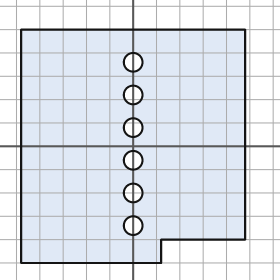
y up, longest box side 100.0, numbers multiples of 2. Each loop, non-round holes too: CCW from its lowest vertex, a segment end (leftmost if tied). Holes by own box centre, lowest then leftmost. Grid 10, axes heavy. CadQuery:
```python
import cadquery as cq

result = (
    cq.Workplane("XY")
    .moveTo(-48.0, -50.0)
    .lineTo(12.0, -50.0)
    .lineTo(12.0, -40.0)
    .lineTo(48.0, -40.0)
    .lineTo(48.0, 50.0)
    .lineTo(-48.0, 50.0)
    .close()
    .moveTo(0.0, -34.0)
    .circle(4.0)
    .moveTo(0.0, -20.0)
    .circle(4.0)
    .moveTo(0.0, -6.0)
    .circle(4.0)
    .moveTo(0.0, 8.0)
    .circle(4.0)
    .moveTo(0.0, 22.0)
    .circle(4.0)
    .moveTo(0.0, 36.0)
    .circle(4.0)
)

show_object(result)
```